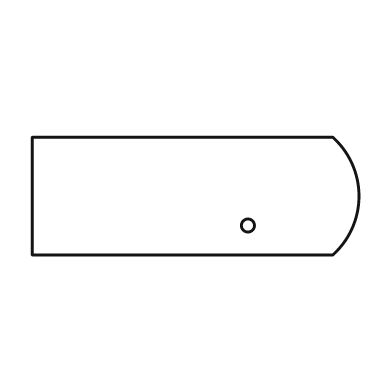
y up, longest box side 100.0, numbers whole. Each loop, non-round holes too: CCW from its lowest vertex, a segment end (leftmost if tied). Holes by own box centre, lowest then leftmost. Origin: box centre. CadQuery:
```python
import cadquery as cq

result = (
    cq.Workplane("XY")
    .moveTo(-50.0, -18.0)
    .lineTo(42.0, -18.0)
    .threePointArc((50.0, 0.0), (42.0, 18.0))
    .lineTo(-50.0, 18.0)
    .close()
    .moveTo(16.0, -9.0)
    .circle(2.0)
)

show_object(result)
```